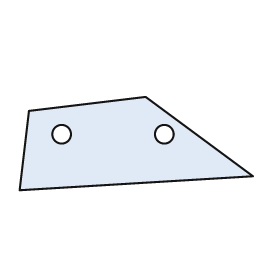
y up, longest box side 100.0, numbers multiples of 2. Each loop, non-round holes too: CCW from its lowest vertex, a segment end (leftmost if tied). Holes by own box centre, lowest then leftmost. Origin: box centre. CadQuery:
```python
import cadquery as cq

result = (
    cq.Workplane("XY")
    .moveTo(-50.0, -20.0)
    .lineTo(50.0, -14.0)
    .lineTo(4.0, 20.0)
    .lineTo(-46.0, 14.0)
    .close()
    .moveTo(-32.0, 4.0)
    .circle(4.0)
    .moveTo(12.0, 4.0)
    .circle(4.0)
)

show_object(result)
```